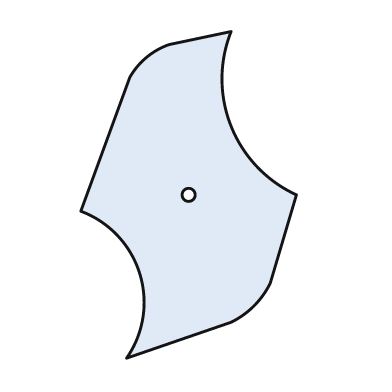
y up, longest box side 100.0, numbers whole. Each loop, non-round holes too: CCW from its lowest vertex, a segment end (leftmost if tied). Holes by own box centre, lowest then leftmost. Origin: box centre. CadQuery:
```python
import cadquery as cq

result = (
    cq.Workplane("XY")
    .moveTo(-19.0, -50.0)
    .lineTo(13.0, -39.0)
    .threePointArc((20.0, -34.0), (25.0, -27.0))
    .lineTo(33.0, 0.0)
    .threePointArc((13.0, 21.0), (13.0, 50.0))
    .lineTo(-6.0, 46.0)
    .threePointArc((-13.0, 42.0), (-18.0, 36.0))
    .lineTo(-33.0, -5.0)
    .threePointArc((-15.0, -24.0), (-19.0, -50.0))
    .close()
    .moveTo(0.0, 0.0)
    .circle(2.0)
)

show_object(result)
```